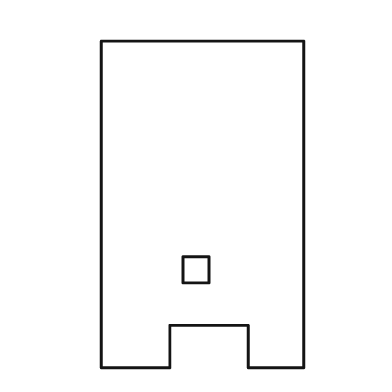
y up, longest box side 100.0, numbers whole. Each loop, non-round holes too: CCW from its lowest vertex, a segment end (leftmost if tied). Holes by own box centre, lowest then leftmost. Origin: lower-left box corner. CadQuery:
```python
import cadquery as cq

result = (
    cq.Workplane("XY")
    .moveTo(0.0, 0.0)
    .lineTo(21.0, 0.0)
    .lineTo(21.0, 13.0)
    .lineTo(45.0, 13.0)
    .lineTo(45.0, 0.0)
    .lineTo(62.0, 0.0)
    .lineTo(62.0, 100.0)
    .lineTo(0.0, 100.0)
    .close()
    .moveTo(25.0, 26.0)
    .lineTo(33.0, 26.0)
    .lineTo(33.0, 34.0)
    .lineTo(25.0, 34.0)
    .close()
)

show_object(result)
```